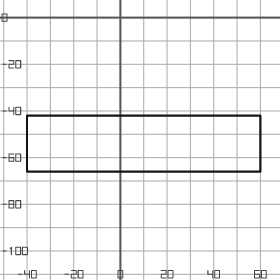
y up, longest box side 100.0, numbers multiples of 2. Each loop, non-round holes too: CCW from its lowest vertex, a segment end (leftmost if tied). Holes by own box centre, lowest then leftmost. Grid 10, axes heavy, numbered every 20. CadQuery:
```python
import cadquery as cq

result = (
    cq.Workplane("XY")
    .moveTo(-40.0, -66.0)
    .lineTo(60.0, -66.0)
    .lineTo(60.0, -42.0)
    .lineTo(-40.0, -42.0)
    .close()
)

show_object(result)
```